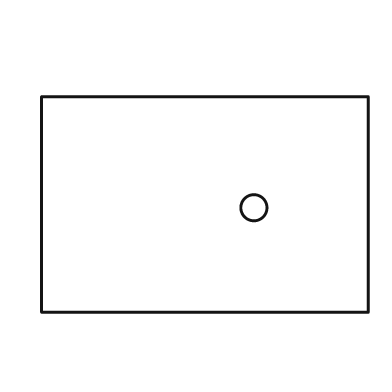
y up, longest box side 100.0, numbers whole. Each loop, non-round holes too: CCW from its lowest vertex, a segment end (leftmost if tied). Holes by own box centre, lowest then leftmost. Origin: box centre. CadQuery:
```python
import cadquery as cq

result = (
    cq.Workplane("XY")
    .moveTo(-50.0, -33.0)
    .lineTo(50.0, -33.0)
    .lineTo(50.0, 33.0)
    .lineTo(-50.0, 33.0)
    .close()
    .moveTo(15.0, -1.0)
    .circle(4.0)
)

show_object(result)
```